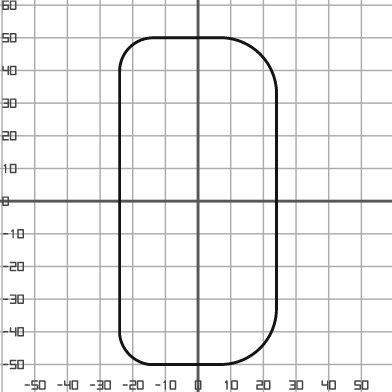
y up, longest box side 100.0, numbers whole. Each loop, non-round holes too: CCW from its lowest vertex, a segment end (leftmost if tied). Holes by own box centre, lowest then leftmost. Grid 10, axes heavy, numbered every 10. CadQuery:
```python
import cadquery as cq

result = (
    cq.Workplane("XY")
    .moveTo(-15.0, -50.0)
    .lineTo(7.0, -50.0)
    .threePointArc((19.0, -45.0), (24.0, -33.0))
    .lineTo(24.0, 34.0)
    .threePointArc((19.0, 45.0), (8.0, 50.0))
    .lineTo(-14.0, 50.0)
    .threePointArc((-21.0, 47.0), (-24.0, 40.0))
    .lineTo(-24.0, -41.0)
    .threePointArc((-21.0, -47.0), (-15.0, -50.0))
    .close()
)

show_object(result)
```